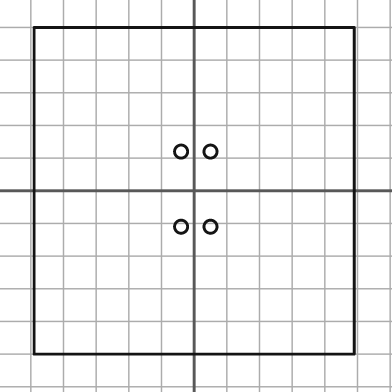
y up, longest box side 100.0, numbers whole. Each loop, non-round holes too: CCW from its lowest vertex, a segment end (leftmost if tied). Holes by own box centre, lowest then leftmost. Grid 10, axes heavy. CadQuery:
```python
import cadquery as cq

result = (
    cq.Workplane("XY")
    .moveTo(-49.0, -50.0)
    .lineTo(49.0, -50.0)
    .lineTo(49.0, 50.0)
    .lineTo(-49.0, 50.0)
    .close()
    .moveTo(-4.0, -11.0)
    .circle(2.0)
    .moveTo(5.0, -11.0)
    .circle(2.0)
    .moveTo(-4.0, 12.0)
    .circle(2.0)
    .moveTo(5.0, 12.0)
    .circle(2.0)
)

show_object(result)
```